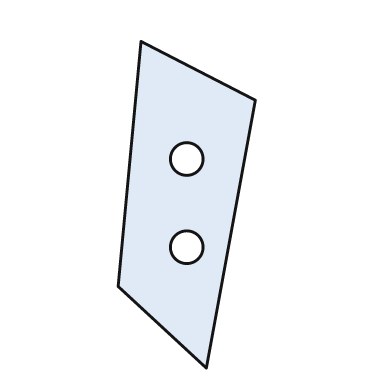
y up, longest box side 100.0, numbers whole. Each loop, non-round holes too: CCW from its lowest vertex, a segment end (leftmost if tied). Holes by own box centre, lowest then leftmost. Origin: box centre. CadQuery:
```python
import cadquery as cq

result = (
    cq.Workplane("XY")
    .moveTo(6.0, -50.0)
    .lineTo(21.0, 32.0)
    .lineTo(-14.0, 50.0)
    .lineTo(-21.0, -25.0)
    .close()
    .moveTo(0.0, -13.0)
    .circle(5.0)
    .moveTo(0.0, 14.0)
    .circle(5.0)
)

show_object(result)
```